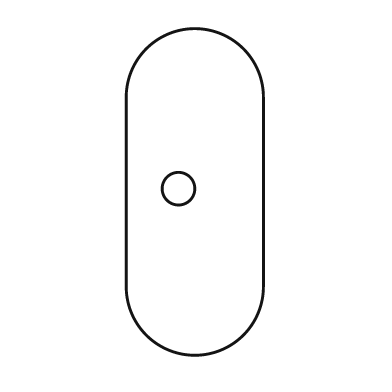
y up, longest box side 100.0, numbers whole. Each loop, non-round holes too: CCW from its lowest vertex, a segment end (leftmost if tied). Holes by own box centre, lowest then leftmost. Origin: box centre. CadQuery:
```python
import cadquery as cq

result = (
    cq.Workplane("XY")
    .moveTo(-21.0, -29.0)
    .threePointArc((0.0, -50.0), (21.0, -29.0))
    .lineTo(21.0, 29.0)
    .threePointArc((0.0, 50.0), (-21.0, 29.0))
    .close()
    .moveTo(-5.0, 1.0)
    .circle(5.0)
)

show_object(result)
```